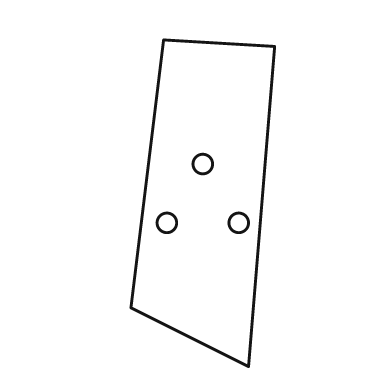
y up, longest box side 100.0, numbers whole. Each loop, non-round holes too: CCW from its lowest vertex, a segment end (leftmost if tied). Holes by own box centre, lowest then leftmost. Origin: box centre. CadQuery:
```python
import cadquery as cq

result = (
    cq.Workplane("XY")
    .moveTo(14.0, -50.0)
    .lineTo(22.0, 48.0)
    .lineTo(-12.0, 50.0)
    .lineTo(-22.0, -32.0)
    .close()
    .moveTo(-11.0, -6.0)
    .circle(3.0)
    .moveTo(11.0, -6.0)
    .circle(3.0)
    .moveTo(0.0, 12.0)
    .circle(3.0)
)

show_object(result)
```